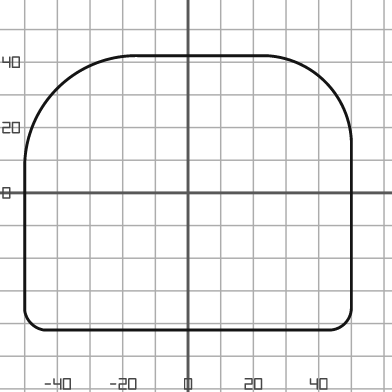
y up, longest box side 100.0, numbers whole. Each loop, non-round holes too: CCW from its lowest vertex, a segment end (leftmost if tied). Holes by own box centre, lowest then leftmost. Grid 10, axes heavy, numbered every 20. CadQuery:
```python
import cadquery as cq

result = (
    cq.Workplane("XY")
    .moveTo(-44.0, -42.0)
    .lineTo(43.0, -42.0)
    .threePointArc((48.0, -40.0), (50.0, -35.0))
    .lineTo(50.0, 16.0)
    .threePointArc((42.0, 34.0), (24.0, 42.0))
    .lineTo(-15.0, 42.0)
    .threePointArc((-40.0, 32.0), (-50.0, 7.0))
    .lineTo(-50.0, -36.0)
    .threePointArc((-48.0, -40.0), (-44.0, -42.0))
    .close()
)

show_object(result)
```